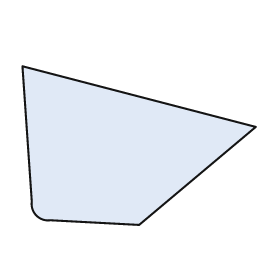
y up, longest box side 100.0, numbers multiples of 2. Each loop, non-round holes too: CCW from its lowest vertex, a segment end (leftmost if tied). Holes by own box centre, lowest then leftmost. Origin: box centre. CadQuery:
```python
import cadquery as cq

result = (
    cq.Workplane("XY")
    .moveTo(0.0, -34.0)
    .lineTo(50.0, 8.0)
    .lineTo(-50.0, 34.0)
    .lineTo(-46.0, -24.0)
    .threePointArc((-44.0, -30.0), (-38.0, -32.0))
    .close()
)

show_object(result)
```